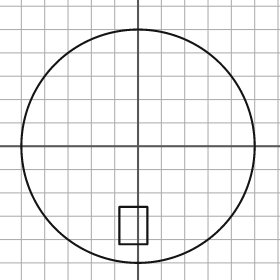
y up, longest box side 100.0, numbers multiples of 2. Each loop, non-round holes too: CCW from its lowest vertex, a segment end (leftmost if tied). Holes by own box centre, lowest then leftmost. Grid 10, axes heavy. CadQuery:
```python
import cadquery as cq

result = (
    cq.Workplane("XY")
    .moveTo(0.0, 0.0)
    .circle(50.0)
    .moveTo(-8.0, -42.0)
    .lineTo(4.0, -42.0)
    .lineTo(4.0, -26.0)
    .lineTo(-8.0, -26.0)
    .close()
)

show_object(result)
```